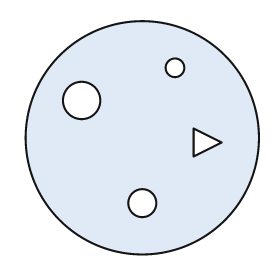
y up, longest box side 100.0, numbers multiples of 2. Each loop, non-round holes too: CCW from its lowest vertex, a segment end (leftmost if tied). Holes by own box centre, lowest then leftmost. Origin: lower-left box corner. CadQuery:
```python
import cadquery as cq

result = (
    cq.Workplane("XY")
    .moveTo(50.0, 50.0)
    .circle(50.0)
    .moveTo(50.0, 22.0)
    .circle(6.0)
    .moveTo(72.0, 42.0)
    .lineTo(84.0, 48.0)
    .lineTo(72.0, 54.0)
    .close()
    .moveTo(24.0, 66.0)
    .circle(8.0)
    .moveTo(64.0, 80.0)
    .circle(4.0)
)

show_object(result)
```